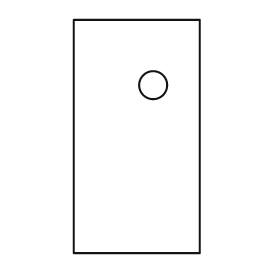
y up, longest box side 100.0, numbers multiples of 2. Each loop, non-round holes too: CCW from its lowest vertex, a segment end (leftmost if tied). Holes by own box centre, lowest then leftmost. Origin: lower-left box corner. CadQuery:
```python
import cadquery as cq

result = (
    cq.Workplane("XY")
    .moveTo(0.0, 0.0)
    .lineTo(54.0, 0.0)
    .lineTo(54.0, 100.0)
    .lineTo(0.0, 100.0)
    .close()
    .moveTo(34.0, 72.0)
    .circle(6.0)
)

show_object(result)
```